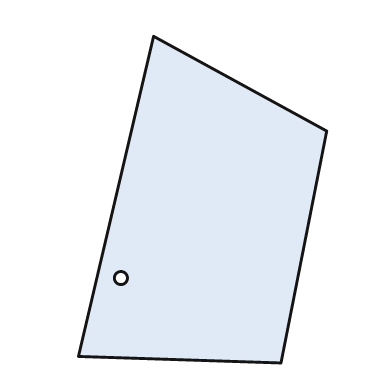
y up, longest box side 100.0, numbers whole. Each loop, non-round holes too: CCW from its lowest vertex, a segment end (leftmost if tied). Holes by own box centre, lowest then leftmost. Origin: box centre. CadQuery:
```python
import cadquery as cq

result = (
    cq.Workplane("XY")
    .moveTo(24.0, -50.0)
    .lineTo(38.0, 21.0)
    .lineTo(-15.0, 50.0)
    .lineTo(-38.0, -48.0)
    .close()
    .moveTo(-25.0, -24.0)
    .circle(2.0)
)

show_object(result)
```